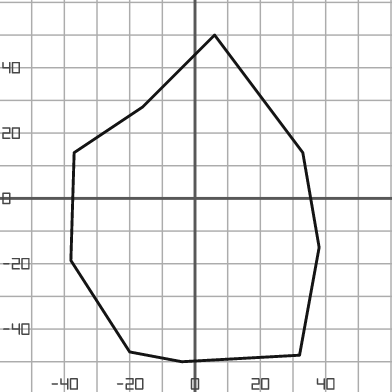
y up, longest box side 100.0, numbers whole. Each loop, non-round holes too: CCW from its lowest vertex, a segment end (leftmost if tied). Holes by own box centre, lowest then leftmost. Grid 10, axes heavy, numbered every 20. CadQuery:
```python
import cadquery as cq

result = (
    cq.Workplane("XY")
    .moveTo(-4.0, -50.0)
    .lineTo(32.0, -48.0)
    .lineTo(38.0, -15.0)
    .lineTo(33.0, 14.0)
    .lineTo(6.0, 50.0)
    .lineTo(-16.0, 28.0)
    .lineTo(-37.0, 14.0)
    .lineTo(-38.0, -19.0)
    .lineTo(-20.0, -47.0)
    .close()
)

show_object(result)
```